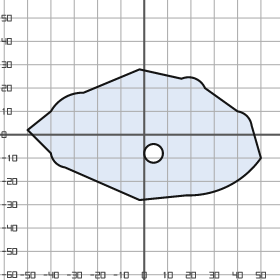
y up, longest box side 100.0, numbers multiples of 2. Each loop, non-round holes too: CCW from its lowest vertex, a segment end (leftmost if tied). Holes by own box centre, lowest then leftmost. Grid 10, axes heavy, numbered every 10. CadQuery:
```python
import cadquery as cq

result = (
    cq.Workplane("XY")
    .moveTo(-2.0, -28.0)
    .lineTo(18.0, -26.0)
    .threePointArc((36.0, -22.0), (50.0, -10.0))
    .lineTo(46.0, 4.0)
    .threePointArc((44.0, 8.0), (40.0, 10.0))
    .lineTo(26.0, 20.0)
    .threePointArc((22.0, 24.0), (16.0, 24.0))
    .lineTo(-2.0, 28.0)
    .lineTo(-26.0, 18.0)
    .threePointArc((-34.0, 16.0), (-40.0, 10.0))
    .lineTo(-50.0, 2.0)
    .lineTo(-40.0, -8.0)
    .threePointArc((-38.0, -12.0), (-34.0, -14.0))
    .close()
    .moveTo(4.0, -8.0)
    .circle(4.0)
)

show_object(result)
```